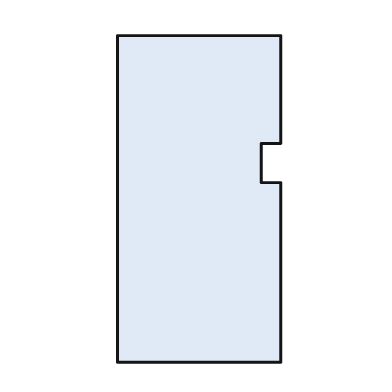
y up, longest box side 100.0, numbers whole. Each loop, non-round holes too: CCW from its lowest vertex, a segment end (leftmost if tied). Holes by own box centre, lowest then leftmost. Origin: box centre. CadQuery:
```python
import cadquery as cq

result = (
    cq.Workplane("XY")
    .moveTo(-25.0, -50.0)
    .lineTo(25.0, -50.0)
    .lineTo(25.0, 5.0)
    .lineTo(19.0, 5.0)
    .lineTo(19.0, 17.0)
    .lineTo(25.0, 17.0)
    .lineTo(25.0, 50.0)
    .lineTo(-25.0, 50.0)
    .close()
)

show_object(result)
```